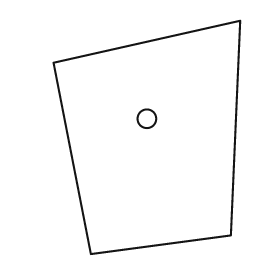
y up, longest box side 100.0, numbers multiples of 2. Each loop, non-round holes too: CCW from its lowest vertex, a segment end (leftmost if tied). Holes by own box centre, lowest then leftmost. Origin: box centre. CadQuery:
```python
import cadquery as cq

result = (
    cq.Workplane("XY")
    .moveTo(-24.0, -50.0)
    .lineTo(36.0, -42.0)
    .lineTo(40.0, 50.0)
    .lineTo(-40.0, 32.0)
    .close()
    .moveTo(0.0, 8.0)
    .circle(4.0)
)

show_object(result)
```